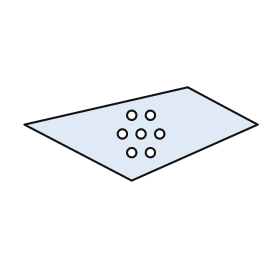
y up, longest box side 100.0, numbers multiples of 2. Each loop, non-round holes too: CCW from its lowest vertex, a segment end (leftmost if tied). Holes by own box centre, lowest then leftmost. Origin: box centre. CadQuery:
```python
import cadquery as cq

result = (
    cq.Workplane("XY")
    .moveTo(-4.0, -20.0)
    .lineTo(50.0, 4.0)
    .lineTo(20.0, 20.0)
    .lineTo(-50.0, 4.0)
    .close()
    .moveTo(-4.0, -8.0)
    .circle(2.0)
    .moveTo(4.0, -8.0)
    .circle(2.0)
    .moveTo(-8.0, 0.0)
    .circle(2.0)
    .moveTo(0.0, 0.0)
    .circle(2.0)
    .moveTo(8.0, 0.0)
    .circle(2.0)
    .moveTo(-4.0, 8.0)
    .circle(2.0)
    .moveTo(4.0, 8.0)
    .circle(2.0)
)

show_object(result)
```